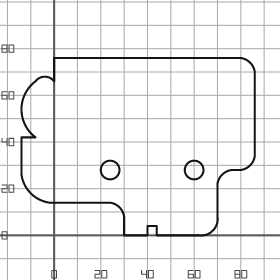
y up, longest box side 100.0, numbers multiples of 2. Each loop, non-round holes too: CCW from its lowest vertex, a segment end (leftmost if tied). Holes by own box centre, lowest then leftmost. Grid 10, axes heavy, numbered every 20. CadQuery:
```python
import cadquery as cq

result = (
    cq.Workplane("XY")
    .moveTo(30.0, 0.0)
    .lineTo(40.0, 0.0)
    .lineTo(40.0, 4.0)
    .lineTo(44.0, 4.0)
    .lineTo(44.0, 0.0)
    .lineTo(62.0, 0.0)
    .threePointArc((68.0, 2.0), (70.0, 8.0))
    .lineTo(70.0, 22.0)
    .threePointArc((72.0, 26.0), (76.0, 28.0))
    .lineTo(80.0, 28.0)
    .threePointArc((84.0, 30.0), (86.0, 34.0))
    .lineTo(86.0, 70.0)
    .threePointArc((84.0, 74.0), (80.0, 76.0))
    .lineTo(0.0, 76.0)
    .lineTo(0.0, 66.0)
    .threePointArc((-4.0, 68.0), (-8.0, 66.0))
    .threePointArc((-14.0, 54.0), (-8.0, 42.0))
    .lineTo(-14.0, 42.0)
    .lineTo(-14.0, 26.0)
    .threePointArc((-10.0, 18.0), (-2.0, 14.0))
    .lineTo(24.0, 14.0)
    .threePointArc((28.0, 12.0), (30.0, 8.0))
    .close()
    .moveTo(24.0, 28.0)
    .circle(4.0)
    .moveTo(60.0, 28.0)
    .circle(4.0)
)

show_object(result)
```